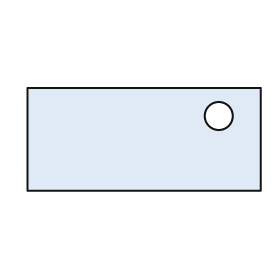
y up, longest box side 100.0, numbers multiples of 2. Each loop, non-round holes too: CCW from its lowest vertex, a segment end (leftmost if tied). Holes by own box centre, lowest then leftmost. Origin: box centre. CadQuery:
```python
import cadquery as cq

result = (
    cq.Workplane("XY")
    .moveTo(-50.0, -22.0)
    .lineTo(50.0, -22.0)
    .lineTo(50.0, 22.0)
    .lineTo(-50.0, 22.0)
    .close()
    .moveTo(32.0, 10.0)
    .circle(6.0)
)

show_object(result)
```